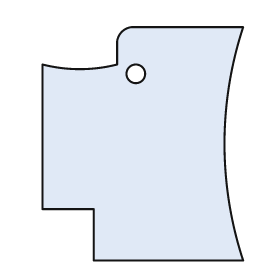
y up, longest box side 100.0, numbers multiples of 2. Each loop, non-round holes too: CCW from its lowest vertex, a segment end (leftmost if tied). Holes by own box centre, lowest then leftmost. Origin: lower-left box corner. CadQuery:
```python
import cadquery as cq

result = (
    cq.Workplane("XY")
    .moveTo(22.0, 0.0)
    .lineTo(86.0, 0.0)
    .threePointArc((78.0, 50.0), (86.0, 100.0))
    .lineTo(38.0, 100.0)
    .threePointArc((34.0, 98.0), (32.0, 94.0))
    .lineTo(32.0, 84.0)
    .threePointArc((16.0, 82.0), (0.0, 84.0))
    .lineTo(0.0, 22.0)
    .lineTo(22.0, 22.0)
    .close()
    .moveTo(40.0, 80.0)
    .circle(4.0)
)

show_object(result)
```